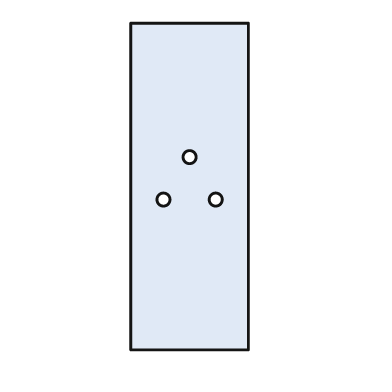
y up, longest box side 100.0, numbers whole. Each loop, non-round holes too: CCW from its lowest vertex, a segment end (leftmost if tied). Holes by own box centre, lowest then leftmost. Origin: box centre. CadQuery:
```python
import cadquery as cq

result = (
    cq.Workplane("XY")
    .moveTo(-18.0, -50.0)
    .lineTo(18.0, -50.0)
    .lineTo(18.0, 50.0)
    .lineTo(-18.0, 50.0)
    .close()
    .moveTo(-8.0, -4.0)
    .circle(2.0)
    .moveTo(8.0, -4.0)
    .circle(2.0)
    .moveTo(0.0, 9.0)
    .circle(2.0)
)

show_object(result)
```